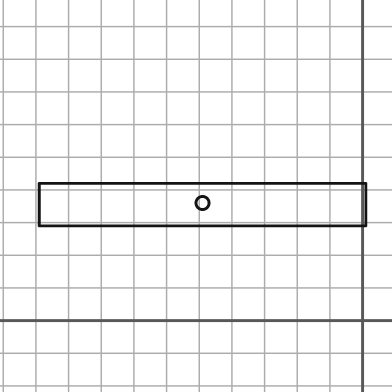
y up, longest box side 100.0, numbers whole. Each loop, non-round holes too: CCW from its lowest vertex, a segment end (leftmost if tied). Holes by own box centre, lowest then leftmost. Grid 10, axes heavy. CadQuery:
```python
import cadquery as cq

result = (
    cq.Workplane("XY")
    .moveTo(-99.0, 29.0)
    .lineTo(1.0, 29.0)
    .lineTo(1.0, 42.0)
    .lineTo(-99.0, 42.0)
    .close()
    .moveTo(-49.0, 36.0)
    .circle(2.0)
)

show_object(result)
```